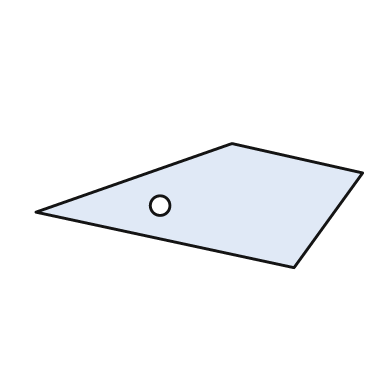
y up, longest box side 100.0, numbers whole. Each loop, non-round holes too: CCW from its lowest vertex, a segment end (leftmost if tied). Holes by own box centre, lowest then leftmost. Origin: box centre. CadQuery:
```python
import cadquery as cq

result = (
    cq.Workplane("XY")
    .moveTo(29.0, -19.0)
    .lineTo(50.0, 10.0)
    .lineTo(10.0, 19.0)
    .lineTo(-50.0, -2.0)
    .close()
    .moveTo(-12.0, 0.0)
    .circle(3.0)
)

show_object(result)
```